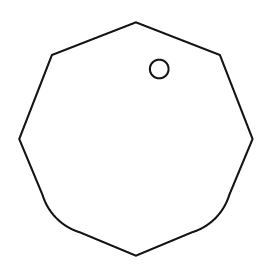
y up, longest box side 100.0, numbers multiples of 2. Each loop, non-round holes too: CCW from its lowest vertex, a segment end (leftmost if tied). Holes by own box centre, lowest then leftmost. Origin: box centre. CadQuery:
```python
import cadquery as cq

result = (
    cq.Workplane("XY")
    .moveTo(0.0, -50.0)
    .lineTo(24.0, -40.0)
    .threePointArc((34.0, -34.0), (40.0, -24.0))
    .lineTo(50.0, 0.0)
    .lineTo(36.0, 36.0)
    .lineTo(0.0, 50.0)
    .lineTo(-36.0, 36.0)
    .lineTo(-50.0, 0.0)
    .lineTo(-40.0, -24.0)
    .threePointArc((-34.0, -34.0), (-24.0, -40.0))
    .close()
    .moveTo(10.0, 30.0)
    .circle(4.0)
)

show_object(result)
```